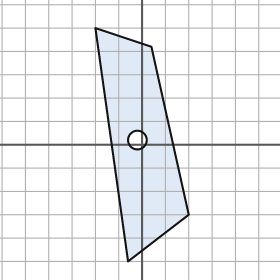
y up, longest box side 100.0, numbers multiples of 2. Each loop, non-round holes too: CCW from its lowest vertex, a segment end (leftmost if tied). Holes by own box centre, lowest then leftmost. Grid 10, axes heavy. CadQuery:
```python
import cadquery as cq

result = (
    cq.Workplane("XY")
    .moveTo(-6.0, -50.0)
    .lineTo(20.0, -30.0)
    .lineTo(4.0, 42.0)
    .lineTo(-20.0, 50.0)
    .close()
    .moveTo(-2.0, 2.0)
    .circle(4.0)
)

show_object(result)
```